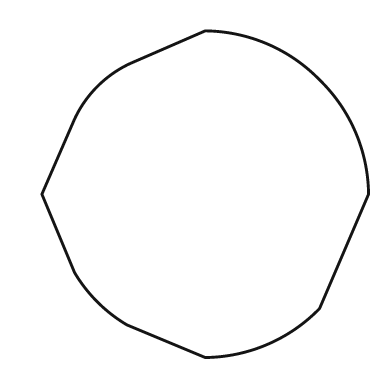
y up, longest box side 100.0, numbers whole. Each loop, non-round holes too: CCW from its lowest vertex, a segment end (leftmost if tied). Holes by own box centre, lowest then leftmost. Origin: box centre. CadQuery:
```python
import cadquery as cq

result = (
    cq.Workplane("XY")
    .moveTo(0.0, -50.0)
    .threePointArc((19.0, -46.0), (35.0, -35.0))
    .lineTo(50.0, 0.0)
    .threePointArc((46.0, 19.0), (35.0, 35.0))
    .threePointArc((19.0, 46.0), (0.0, 50.0))
    .lineTo(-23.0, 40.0)
    .threePointArc((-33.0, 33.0), (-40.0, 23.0))
    .lineTo(-50.0, 0.0)
    .lineTo(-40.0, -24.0)
    .threePointArc((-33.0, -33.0), (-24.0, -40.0))
    .close()
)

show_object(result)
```